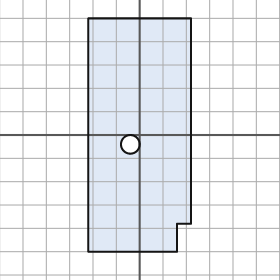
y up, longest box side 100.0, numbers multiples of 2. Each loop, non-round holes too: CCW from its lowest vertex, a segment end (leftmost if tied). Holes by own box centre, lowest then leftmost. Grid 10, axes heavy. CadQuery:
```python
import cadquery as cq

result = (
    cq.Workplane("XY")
    .moveTo(-22.0, -50.0)
    .lineTo(16.0, -50.0)
    .lineTo(16.0, -38.0)
    .lineTo(22.0, -38.0)
    .lineTo(22.0, 50.0)
    .lineTo(-22.0, 50.0)
    .close()
    .moveTo(-4.0, -4.0)
    .circle(4.0)
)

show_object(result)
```